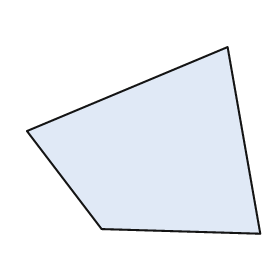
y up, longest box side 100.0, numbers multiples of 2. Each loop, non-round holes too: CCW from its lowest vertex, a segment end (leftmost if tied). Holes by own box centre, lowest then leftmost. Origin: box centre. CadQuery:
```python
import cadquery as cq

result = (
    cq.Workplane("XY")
    .moveTo(50.0, -40.0)
    .lineTo(36.0, 40.0)
    .lineTo(-50.0, 4.0)
    .lineTo(-18.0, -38.0)
    .close()
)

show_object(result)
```